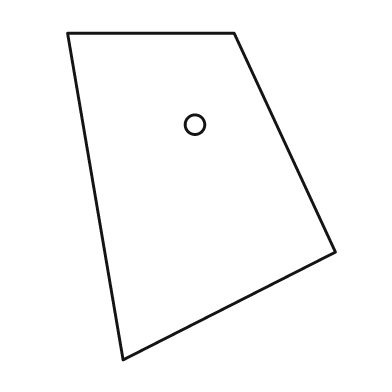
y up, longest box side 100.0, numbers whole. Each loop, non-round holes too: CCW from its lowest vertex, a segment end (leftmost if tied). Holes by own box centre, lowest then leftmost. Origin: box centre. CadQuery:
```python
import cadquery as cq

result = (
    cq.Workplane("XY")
    .moveTo(-24.0, -50.0)
    .lineTo(41.0, -17.0)
    .lineTo(10.0, 50.0)
    .lineTo(-41.0, 50.0)
    .close()
    .moveTo(-2.0, 22.0)
    .circle(3.0)
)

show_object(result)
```